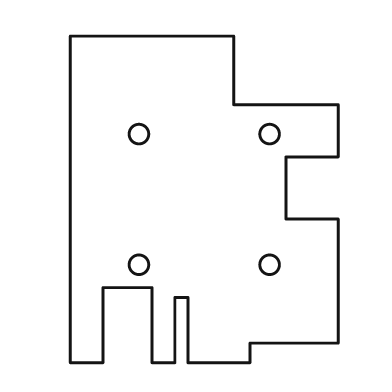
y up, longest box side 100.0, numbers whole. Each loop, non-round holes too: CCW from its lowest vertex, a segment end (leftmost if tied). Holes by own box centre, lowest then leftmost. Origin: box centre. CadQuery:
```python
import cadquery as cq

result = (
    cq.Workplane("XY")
    .moveTo(-41.0, -50.0)
    .lineTo(-31.0, -50.0)
    .lineTo(-31.0, -27.0)
    .lineTo(-16.0, -27.0)
    .lineTo(-16.0, -50.0)
    .lineTo(-9.0, -50.0)
    .lineTo(-9.0, -30.0)
    .lineTo(-5.0, -30.0)
    .lineTo(-5.0, -50.0)
    .lineTo(14.0, -50.0)
    .lineTo(14.0, -44.0)
    .lineTo(41.0, -44.0)
    .lineTo(41.0, -6.0)
    .lineTo(25.0, -6.0)
    .lineTo(25.0, 13.0)
    .lineTo(41.0, 13.0)
    .lineTo(41.0, 29.0)
    .lineTo(9.0, 29.0)
    .lineTo(9.0, 50.0)
    .lineTo(-41.0, 50.0)
    .close()
    .moveTo(-20.0, -20.0)
    .circle(3.0)
    .moveTo(20.0, -20.0)
    .circle(3.0)
    .moveTo(-20.0, 20.0)
    .circle(3.0)
    .moveTo(20.0, 20.0)
    .circle(3.0)
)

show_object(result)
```